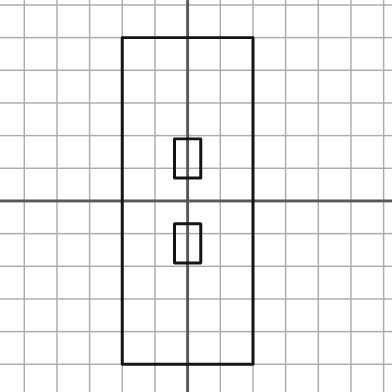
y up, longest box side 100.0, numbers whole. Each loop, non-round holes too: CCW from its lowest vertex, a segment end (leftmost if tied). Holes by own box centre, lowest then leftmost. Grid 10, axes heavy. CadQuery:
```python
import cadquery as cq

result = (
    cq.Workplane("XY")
    .moveTo(-20.0, -50.0)
    .lineTo(20.0, -50.0)
    .lineTo(20.0, 50.0)
    .lineTo(-20.0, 50.0)
    .close()
    .moveTo(-4.0, -19.0)
    .lineTo(4.0, -19.0)
    .lineTo(4.0, -7.0)
    .lineTo(-4.0, -7.0)
    .close()
    .moveTo(-4.0, 7.0)
    .lineTo(4.0, 7.0)
    .lineTo(4.0, 19.0)
    .lineTo(-4.0, 19.0)
    .close()
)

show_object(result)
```